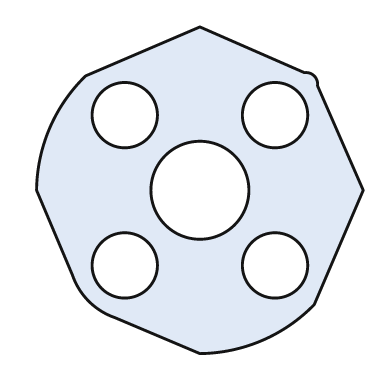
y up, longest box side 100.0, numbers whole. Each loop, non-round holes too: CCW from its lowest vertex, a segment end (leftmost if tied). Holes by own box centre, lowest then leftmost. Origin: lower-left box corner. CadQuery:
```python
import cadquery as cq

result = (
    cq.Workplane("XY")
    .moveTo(50.0, 0.0)
    .threePointArc((69.0, 4.0), (85.0, 15.0))
    .lineTo(100.0, 50.0)
    .lineTo(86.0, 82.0)
    .threePointArc((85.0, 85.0), (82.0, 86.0))
    .lineTo(50.0, 100.0)
    .lineTo(15.0, 85.0)
    .threePointArc((4.0, 69.0), (0.0, 50.0))
    .lineTo(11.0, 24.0)
    .threePointArc((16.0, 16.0), (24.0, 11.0))
    .close()
    .moveTo(27.0, 27.0)
    .circle(10.0)
    .moveTo(73.0, 27.0)
    .circle(10.0)
    .moveTo(50.0, 50.0)
    .circle(15.0)
    .moveTo(27.0, 73.0)
    .circle(10.0)
    .moveTo(73.0, 73.0)
    .circle(10.0)
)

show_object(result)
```